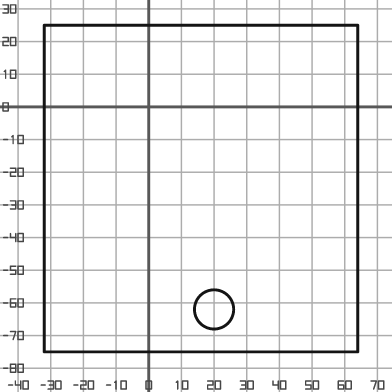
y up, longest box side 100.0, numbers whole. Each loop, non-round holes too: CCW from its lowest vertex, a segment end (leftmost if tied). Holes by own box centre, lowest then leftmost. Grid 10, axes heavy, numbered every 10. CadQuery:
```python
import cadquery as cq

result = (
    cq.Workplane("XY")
    .moveTo(-32.0, -75.0)
    .lineTo(64.0, -75.0)
    .lineTo(64.0, 25.0)
    .lineTo(-32.0, 25.0)
    .close()
    .moveTo(20.0, -62.0)
    .circle(6.0)
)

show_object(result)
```